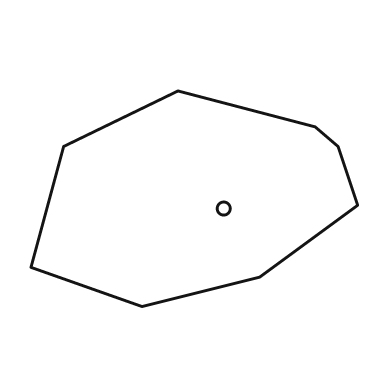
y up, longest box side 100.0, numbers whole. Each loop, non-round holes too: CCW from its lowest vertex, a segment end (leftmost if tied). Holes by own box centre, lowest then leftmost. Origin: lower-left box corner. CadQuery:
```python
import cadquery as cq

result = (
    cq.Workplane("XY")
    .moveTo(34.0, 0.0)
    .lineTo(70.0, 9.0)
    .lineTo(100.0, 31.0)
    .lineTo(94.0, 49.0)
    .lineTo(87.0, 55.0)
    .lineTo(45.0, 66.0)
    .lineTo(10.0, 49.0)
    .lineTo(0.0, 12.0)
    .close()
    .moveTo(59.0, 30.0)
    .circle(2.0)
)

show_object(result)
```